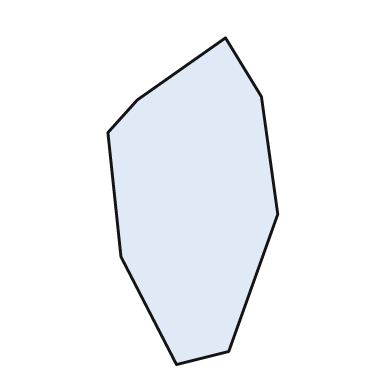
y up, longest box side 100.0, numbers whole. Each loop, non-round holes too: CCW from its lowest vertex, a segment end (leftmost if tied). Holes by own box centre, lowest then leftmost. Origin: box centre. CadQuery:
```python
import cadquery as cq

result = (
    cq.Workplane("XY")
    .moveTo(-5.0, -50.0)
    .lineTo(11.0, -46.0)
    .lineTo(26.0, -4.0)
    .lineTo(21.0, 32.0)
    .lineTo(10.0, 50.0)
    .lineTo(-17.0, 31.0)
    .lineTo(-26.0, 21.0)
    .lineTo(-22.0, -17.0)
    .close()
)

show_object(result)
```